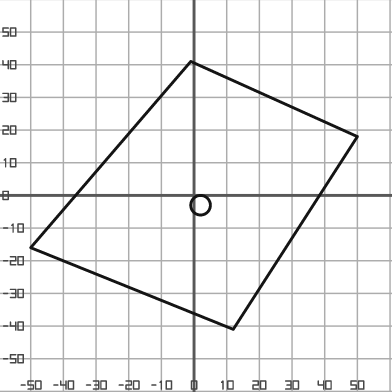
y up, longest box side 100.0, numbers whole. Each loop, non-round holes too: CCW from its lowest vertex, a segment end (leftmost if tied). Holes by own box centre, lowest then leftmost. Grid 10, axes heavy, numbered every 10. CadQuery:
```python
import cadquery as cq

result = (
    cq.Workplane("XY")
    .moveTo(12.0, -41.0)
    .lineTo(50.0, 18.0)
    .lineTo(-1.0, 41.0)
    .lineTo(-50.0, -16.0)
    .close()
    .moveTo(2.0, -3.0)
    .circle(3.0)
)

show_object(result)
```